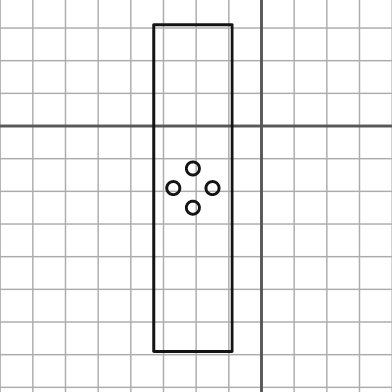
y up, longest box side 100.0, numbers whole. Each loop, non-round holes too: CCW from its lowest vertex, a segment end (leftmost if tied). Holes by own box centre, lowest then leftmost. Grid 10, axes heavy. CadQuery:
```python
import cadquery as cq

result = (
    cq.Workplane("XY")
    .moveTo(-33.0, -69.0)
    .lineTo(-9.0, -69.0)
    .lineTo(-9.0, 31.0)
    .lineTo(-33.0, 31.0)
    .close()
    .moveTo(-21.0, -25.0)
    .circle(2.0)
    .moveTo(-27.0, -19.0)
    .circle(2.0)
    .moveTo(-15.0, -19.0)
    .circle(2.0)
    .moveTo(-21.0, -13.0)
    .circle(2.0)
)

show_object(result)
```